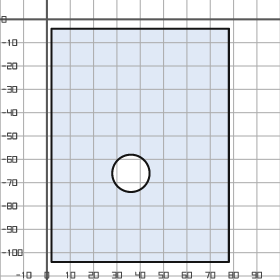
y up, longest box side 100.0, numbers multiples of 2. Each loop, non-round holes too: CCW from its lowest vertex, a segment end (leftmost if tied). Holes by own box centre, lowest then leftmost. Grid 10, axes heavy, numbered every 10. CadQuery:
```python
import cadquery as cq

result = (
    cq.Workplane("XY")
    .moveTo(2.0, -104.0)
    .lineTo(78.0, -104.0)
    .lineTo(78.0, -4.0)
    .lineTo(2.0, -4.0)
    .close()
    .moveTo(36.0, -66.0)
    .circle(8.0)
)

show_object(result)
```